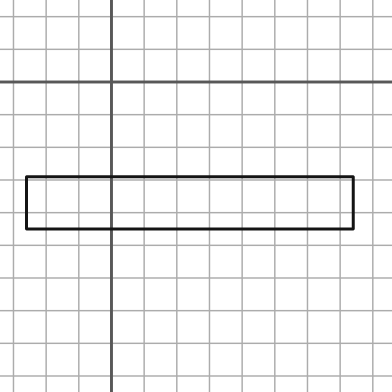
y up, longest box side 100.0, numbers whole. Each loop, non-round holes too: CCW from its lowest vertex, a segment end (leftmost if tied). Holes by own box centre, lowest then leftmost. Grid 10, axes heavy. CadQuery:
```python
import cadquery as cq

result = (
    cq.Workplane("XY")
    .moveTo(-26.0, -45.0)
    .lineTo(74.0, -45.0)
    .lineTo(74.0, -29.0)
    .lineTo(-26.0, -29.0)
    .close()
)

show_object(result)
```